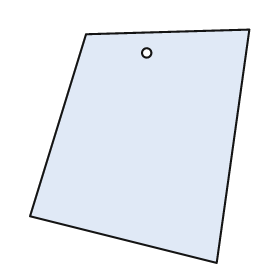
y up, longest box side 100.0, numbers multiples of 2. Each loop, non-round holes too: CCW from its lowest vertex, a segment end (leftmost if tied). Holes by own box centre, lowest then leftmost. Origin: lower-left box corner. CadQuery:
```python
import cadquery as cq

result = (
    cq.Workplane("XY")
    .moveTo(80.0, 0.0)
    .lineTo(94.0, 100.0)
    .lineTo(24.0, 98.0)
    .lineTo(0.0, 20.0)
    .close()
    .moveTo(50.0, 90.0)
    .circle(2.0)
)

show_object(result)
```